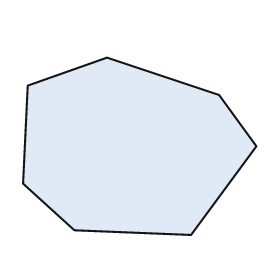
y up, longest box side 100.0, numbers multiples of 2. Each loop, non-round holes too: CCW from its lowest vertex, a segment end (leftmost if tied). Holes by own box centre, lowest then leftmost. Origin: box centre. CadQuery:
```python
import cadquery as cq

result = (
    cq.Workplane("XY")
    .moveTo(22.0, -38.0)
    .lineTo(50.0, 0.0)
    .lineTo(34.0, 22.0)
    .lineTo(-14.0, 38.0)
    .lineTo(-48.0, 26.0)
    .lineTo(-50.0, -16.0)
    .lineTo(-28.0, -36.0)
    .close()
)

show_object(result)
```